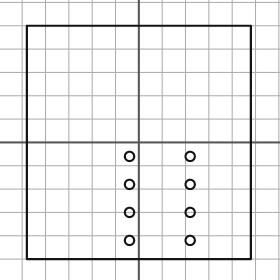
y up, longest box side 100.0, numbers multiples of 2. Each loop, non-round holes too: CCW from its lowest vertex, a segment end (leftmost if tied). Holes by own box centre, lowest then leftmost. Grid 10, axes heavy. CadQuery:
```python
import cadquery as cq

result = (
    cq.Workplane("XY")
    .moveTo(-48.0, -50.0)
    .lineTo(48.0, -50.0)
    .lineTo(48.0, 50.0)
    .lineTo(-48.0, 50.0)
    .close()
    .moveTo(-4.0, -42.0)
    .circle(2.0)
    .moveTo(22.0, -42.0)
    .circle(2.0)
    .moveTo(-4.0, -30.0)
    .circle(2.0)
    .moveTo(22.0, -30.0)
    .circle(2.0)
    .moveTo(-4.0, -18.0)
    .circle(2.0)
    .moveTo(22.0, -18.0)
    .circle(2.0)
    .moveTo(-4.0, -6.0)
    .circle(2.0)
    .moveTo(22.0, -6.0)
    .circle(2.0)
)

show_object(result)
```